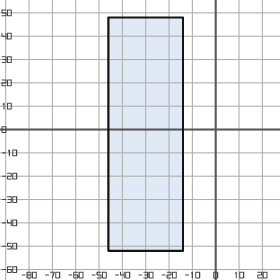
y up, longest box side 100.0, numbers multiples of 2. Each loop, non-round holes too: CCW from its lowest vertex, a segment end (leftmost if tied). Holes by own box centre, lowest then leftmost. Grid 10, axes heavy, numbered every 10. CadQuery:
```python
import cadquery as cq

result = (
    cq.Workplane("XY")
    .moveTo(-46.0, -52.0)
    .lineTo(-14.0, -52.0)
    .lineTo(-14.0, 48.0)
    .lineTo(-46.0, 48.0)
    .close()
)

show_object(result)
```